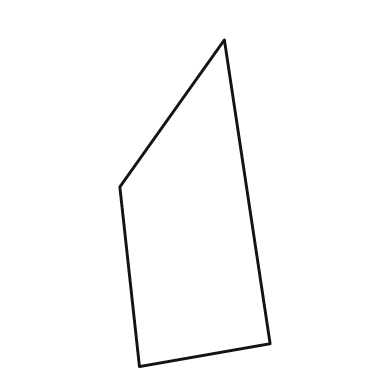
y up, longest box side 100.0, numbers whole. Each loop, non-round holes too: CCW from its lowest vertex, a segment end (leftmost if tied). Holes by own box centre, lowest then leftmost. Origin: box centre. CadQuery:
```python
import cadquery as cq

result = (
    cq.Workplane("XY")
    .moveTo(-17.0, -50.0)
    .lineTo(23.0, -43.0)
    .lineTo(9.0, 50.0)
    .lineTo(-23.0, 5.0)
    .close()
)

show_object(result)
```